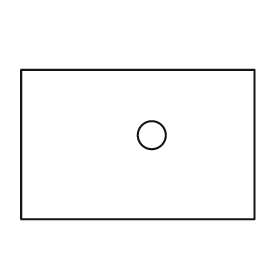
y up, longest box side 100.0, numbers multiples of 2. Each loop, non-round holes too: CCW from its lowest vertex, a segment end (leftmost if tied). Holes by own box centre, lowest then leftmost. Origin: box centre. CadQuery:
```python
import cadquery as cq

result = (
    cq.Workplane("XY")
    .moveTo(-50.0, -32.0)
    .lineTo(50.0, -32.0)
    .lineTo(50.0, 32.0)
    .lineTo(-50.0, 32.0)
    .close()
    .moveTo(6.0, 4.0)
    .circle(6.0)
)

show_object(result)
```